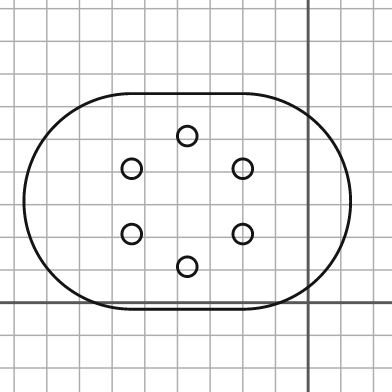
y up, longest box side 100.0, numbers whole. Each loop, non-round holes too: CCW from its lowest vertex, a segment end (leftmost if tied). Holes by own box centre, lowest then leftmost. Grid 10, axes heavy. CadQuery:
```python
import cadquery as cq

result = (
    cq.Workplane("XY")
    .moveTo(-54.0, -2.0)
    .lineTo(-20.0, -2.0)
    .threePointArc((13.0, 31.0), (-20.0, 64.0))
    .lineTo(-54.0, 64.0)
    .threePointArc((-87.0, 31.0), (-54.0, -2.0))
    .close()
    .moveTo(-37.0, 11.0)
    .circle(3.0)
    .moveTo(-54.0, 21.0)
    .circle(3.0)
    .moveTo(-20.0, 21.0)
    .circle(3.0)
    .moveTo(-54.0, 41.0)
    .circle(3.0)
    .moveTo(-20.0, 41.0)
    .circle(3.0)
    .moveTo(-37.0, 51.0)
    .circle(3.0)
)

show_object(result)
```